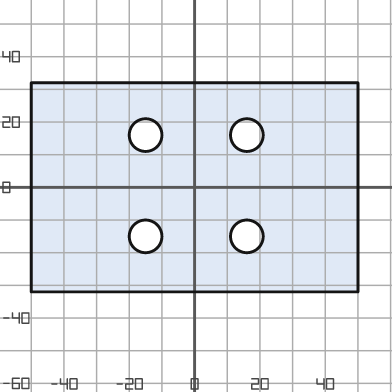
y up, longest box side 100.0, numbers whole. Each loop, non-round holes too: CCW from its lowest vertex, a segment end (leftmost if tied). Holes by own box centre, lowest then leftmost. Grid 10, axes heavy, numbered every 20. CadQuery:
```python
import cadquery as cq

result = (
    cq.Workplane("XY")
    .moveTo(-50.0, -32.0)
    .lineTo(50.0, -32.0)
    .lineTo(50.0, 32.0)
    .lineTo(-50.0, 32.0)
    .close()
    .moveTo(-15.0, -15.0)
    .circle(5.0)
    .moveTo(16.0, -15.0)
    .circle(5.0)
    .moveTo(-15.0, 16.0)
    .circle(5.0)
    .moveTo(16.0, 16.0)
    .circle(5.0)
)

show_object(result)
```